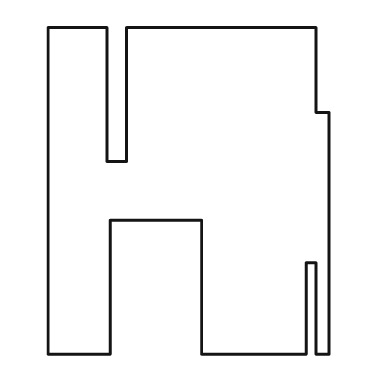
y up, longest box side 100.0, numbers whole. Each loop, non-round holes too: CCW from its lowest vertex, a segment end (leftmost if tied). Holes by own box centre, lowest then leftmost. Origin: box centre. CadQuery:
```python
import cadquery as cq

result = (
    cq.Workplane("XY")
    .moveTo(-43.0, -50.0)
    .lineTo(-24.0, -50.0)
    .lineTo(-24.0, -9.0)
    .lineTo(4.0, -9.0)
    .lineTo(4.0, -50.0)
    .lineTo(36.0, -50.0)
    .lineTo(36.0, -22.0)
    .lineTo(39.0, -22.0)
    .lineTo(39.0, -50.0)
    .lineTo(43.0, -50.0)
    .lineTo(43.0, 24.0)
    .lineTo(39.0, 24.0)
    .lineTo(39.0, 50.0)
    .lineTo(-19.0, 50.0)
    .lineTo(-19.0, 9.0)
    .lineTo(-25.0, 9.0)
    .lineTo(-25.0, 50.0)
    .lineTo(-43.0, 50.0)
    .close()
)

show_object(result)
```